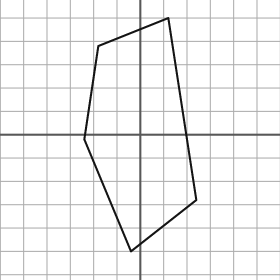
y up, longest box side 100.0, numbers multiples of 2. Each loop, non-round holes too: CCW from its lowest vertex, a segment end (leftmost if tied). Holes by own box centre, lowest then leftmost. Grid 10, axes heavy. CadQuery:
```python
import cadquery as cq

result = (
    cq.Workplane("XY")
    .moveTo(-4.0, -50.0)
    .lineTo(24.0, -28.0)
    .lineTo(12.0, 50.0)
    .lineTo(-18.0, 38.0)
    .lineTo(-24.0, -2.0)
    .close()
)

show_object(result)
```